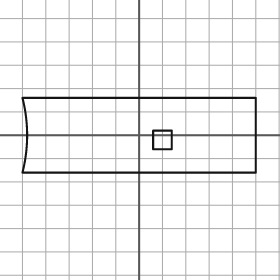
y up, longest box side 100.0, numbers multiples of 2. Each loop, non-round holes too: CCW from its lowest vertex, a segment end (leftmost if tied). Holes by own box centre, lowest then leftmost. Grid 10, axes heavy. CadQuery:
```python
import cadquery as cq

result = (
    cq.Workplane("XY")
    .moveTo(-50.0, -16.0)
    .lineTo(50.0, -16.0)
    .lineTo(50.0, 16.0)
    .lineTo(-50.0, 16.0)
    .threePointArc((-48.0, 0.0), (-50.0, -16.0))
    .close()
    .moveTo(6.0, -6.0)
    .lineTo(14.0, -6.0)
    .lineTo(14.0, 2.0)
    .lineTo(6.0, 2.0)
    .close()
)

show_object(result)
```